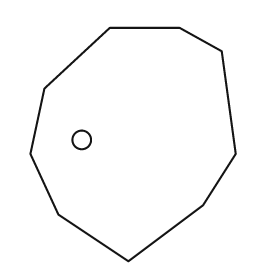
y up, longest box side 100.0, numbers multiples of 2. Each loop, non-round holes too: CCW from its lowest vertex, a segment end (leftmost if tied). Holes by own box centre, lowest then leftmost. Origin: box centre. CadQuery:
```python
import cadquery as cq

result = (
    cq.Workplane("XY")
    .moveTo(-2.0, -50.0)
    .lineTo(30.0, -26.0)
    .lineTo(44.0, -4.0)
    .lineTo(38.0, 40.0)
    .lineTo(20.0, 50.0)
    .lineTo(-10.0, 50.0)
    .lineTo(-38.0, 24.0)
    .lineTo(-44.0, -4.0)
    .lineTo(-32.0, -30.0)
    .close()
    .moveTo(-22.0, 2.0)
    .circle(4.0)
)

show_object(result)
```